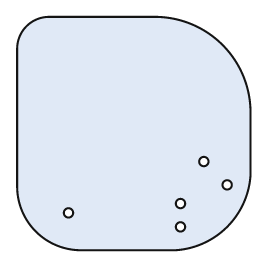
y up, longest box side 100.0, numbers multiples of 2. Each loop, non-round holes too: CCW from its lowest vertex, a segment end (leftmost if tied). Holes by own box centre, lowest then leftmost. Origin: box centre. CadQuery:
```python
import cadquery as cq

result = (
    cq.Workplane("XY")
    .moveTo(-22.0, -50.0)
    .lineTo(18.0, -50.0)
    .threePointArc((40.0, -40.0), (50.0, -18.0))
    .lineTo(50.0, 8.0)
    .threePointArc((38.0, 38.0), (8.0, 50.0))
    .lineTo(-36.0, 50.0)
    .threePointArc((-46.0, 46.0), (-50.0, 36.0))
    .lineTo(-50.0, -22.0)
    .threePointArc((-42.0, -42.0), (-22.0, -50.0))
    .close()
    .moveTo(20.0, -40.0)
    .circle(2.0)
    .moveTo(-28.0, -34.0)
    .circle(2.0)
    .moveTo(20.0, -30.0)
    .circle(2.0)
    .moveTo(40.0, -22.0)
    .circle(2.0)
    .moveTo(30.0, -12.0)
    .circle(2.0)
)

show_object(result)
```